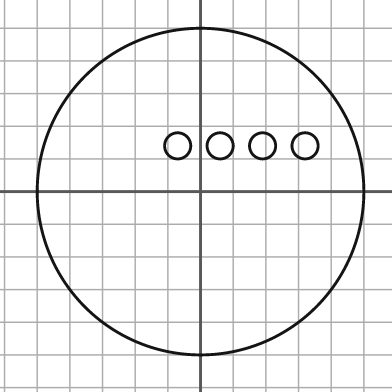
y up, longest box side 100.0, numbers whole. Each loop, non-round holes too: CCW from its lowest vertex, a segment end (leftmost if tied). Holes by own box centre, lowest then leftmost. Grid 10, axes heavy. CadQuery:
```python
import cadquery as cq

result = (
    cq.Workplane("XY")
    .moveTo(0.0, 0.0)
    .circle(50.0)
    .moveTo(-7.0, 14.0)
    .circle(4.0)
    .moveTo(6.0, 14.0)
    .circle(4.0)
    .moveTo(19.0, 14.0)
    .circle(4.0)
    .moveTo(32.0, 14.0)
    .circle(4.0)
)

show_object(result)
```